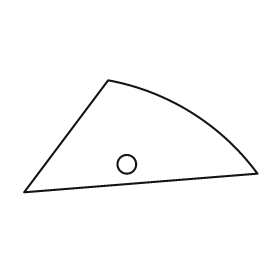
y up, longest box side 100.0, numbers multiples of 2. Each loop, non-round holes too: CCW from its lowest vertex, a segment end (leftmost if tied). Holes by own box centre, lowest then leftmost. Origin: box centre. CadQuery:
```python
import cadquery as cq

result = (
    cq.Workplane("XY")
    .moveTo(-50.0, -24.0)
    .lineTo(50.0, -16.0)
    .threePointArc((22.0, 10.0), (-14.0, 24.0))
    .close()
    .moveTo(-6.0, -12.0)
    .circle(4.0)
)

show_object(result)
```